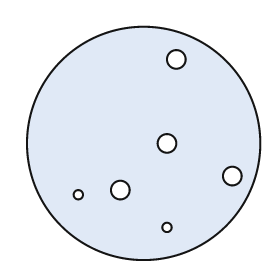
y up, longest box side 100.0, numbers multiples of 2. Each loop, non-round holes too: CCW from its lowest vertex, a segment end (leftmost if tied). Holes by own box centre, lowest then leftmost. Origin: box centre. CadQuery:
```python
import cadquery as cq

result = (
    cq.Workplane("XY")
    .moveTo(0.0, 0.0)
    .circle(50.0)
    .moveTo(10.0, -36.0)
    .circle(2.0)
    .moveTo(-28.0, -22.0)
    .circle(2.0)
    .moveTo(-10.0, -20.0)
    .circle(4.0)
    .moveTo(38.0, -14.0)
    .circle(4.0)
    .moveTo(10.0, 0.0)
    .circle(4.0)
    .moveTo(14.0, 36.0)
    .circle(4.0)
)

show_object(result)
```